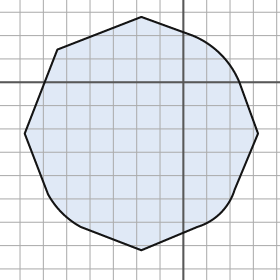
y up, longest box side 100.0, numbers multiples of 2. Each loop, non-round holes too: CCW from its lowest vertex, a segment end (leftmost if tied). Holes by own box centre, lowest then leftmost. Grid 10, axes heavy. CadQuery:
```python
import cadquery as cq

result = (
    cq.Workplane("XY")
    .moveTo(-18.0, -72.0)
    .lineTo(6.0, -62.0)
    .threePointArc((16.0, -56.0), (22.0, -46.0))
    .lineTo(32.0, -22.0)
    .lineTo(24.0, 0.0)
    .threePointArc((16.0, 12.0), (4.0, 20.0))
    .lineTo(-18.0, 28.0)
    .lineTo(-54.0, 14.0)
    .lineTo(-68.0, -22.0)
    .lineTo(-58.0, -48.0)
    .threePointArc((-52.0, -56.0), (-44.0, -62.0))
    .close()
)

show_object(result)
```